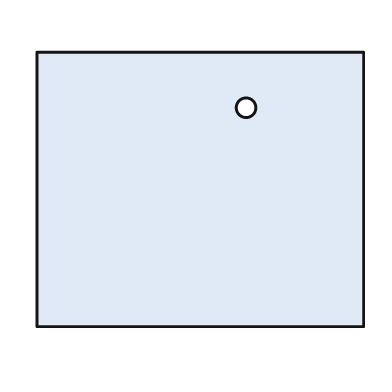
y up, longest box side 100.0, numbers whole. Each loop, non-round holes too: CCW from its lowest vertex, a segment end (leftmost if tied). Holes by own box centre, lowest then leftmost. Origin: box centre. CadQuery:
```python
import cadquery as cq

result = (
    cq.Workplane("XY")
    .moveTo(-50.0, -42.0)
    .lineTo(50.0, -42.0)
    .lineTo(50.0, 42.0)
    .lineTo(-50.0, 42.0)
    .close()
    .moveTo(14.0, 25.0)
    .circle(3.0)
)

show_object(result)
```